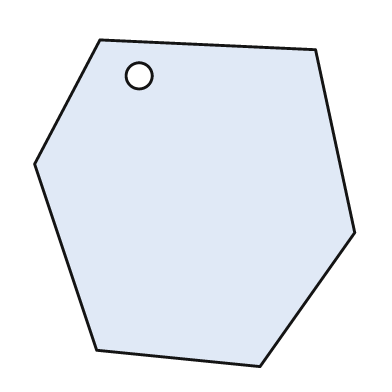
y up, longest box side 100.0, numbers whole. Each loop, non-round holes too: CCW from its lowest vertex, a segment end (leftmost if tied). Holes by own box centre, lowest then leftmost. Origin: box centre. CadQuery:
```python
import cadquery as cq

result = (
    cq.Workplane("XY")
    .moveTo(20.0, -50.0)
    .lineTo(49.0, -9.0)
    .lineTo(37.0, 47.0)
    .lineTo(-29.0, 50.0)
    .lineTo(-49.0, 12.0)
    .lineTo(-30.0, -45.0)
    .close()
    .moveTo(-17.0, 39.0)
    .circle(4.0)
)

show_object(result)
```